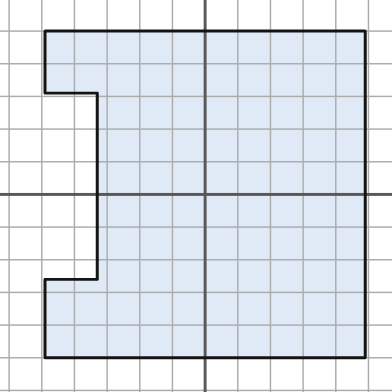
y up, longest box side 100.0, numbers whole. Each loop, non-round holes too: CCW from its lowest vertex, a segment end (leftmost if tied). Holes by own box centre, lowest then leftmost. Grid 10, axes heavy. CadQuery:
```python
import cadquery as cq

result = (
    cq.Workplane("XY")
    .moveTo(-49.0, -50.0)
    .lineTo(49.0, -50.0)
    .lineTo(49.0, 50.0)
    .lineTo(-49.0, 50.0)
    .lineTo(-49.0, 31.0)
    .lineTo(-33.0, 31.0)
    .lineTo(-33.0, -26.0)
    .lineTo(-49.0, -26.0)
    .close()
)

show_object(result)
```